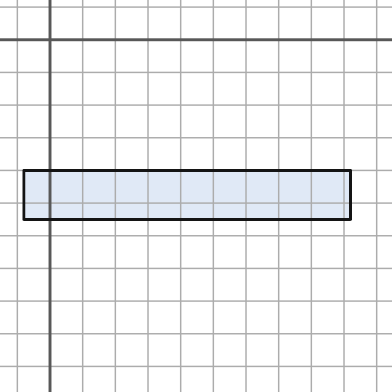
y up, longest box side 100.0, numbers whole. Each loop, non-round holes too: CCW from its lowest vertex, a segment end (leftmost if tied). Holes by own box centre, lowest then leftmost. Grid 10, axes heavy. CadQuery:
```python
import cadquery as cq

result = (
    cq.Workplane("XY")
    .moveTo(-8.0, -55.0)
    .lineTo(92.0, -55.0)
    .lineTo(92.0, -40.0)
    .lineTo(-8.0, -40.0)
    .close()
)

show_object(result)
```